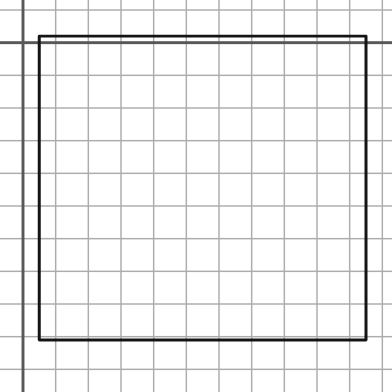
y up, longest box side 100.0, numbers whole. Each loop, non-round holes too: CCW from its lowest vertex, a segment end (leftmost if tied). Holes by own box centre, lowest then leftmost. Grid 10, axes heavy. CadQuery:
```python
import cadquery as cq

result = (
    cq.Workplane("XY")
    .moveTo(5.0, -91.0)
    .lineTo(105.0, -91.0)
    .lineTo(105.0, 2.0)
    .lineTo(5.0, 2.0)
    .close()
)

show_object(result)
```